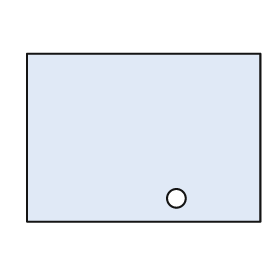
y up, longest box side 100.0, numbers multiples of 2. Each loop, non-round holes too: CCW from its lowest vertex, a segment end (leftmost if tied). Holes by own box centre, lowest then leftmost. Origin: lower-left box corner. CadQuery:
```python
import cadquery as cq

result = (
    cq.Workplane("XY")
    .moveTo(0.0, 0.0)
    .lineTo(100.0, 0.0)
    .lineTo(100.0, 72.0)
    .lineTo(0.0, 72.0)
    .close()
    .moveTo(64.0, 10.0)
    .circle(4.0)
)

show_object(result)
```